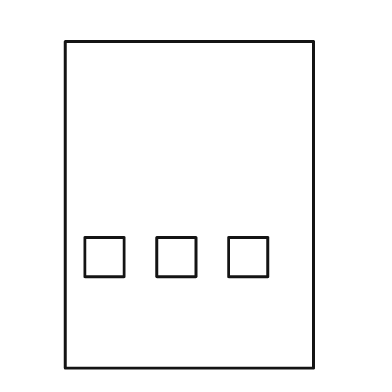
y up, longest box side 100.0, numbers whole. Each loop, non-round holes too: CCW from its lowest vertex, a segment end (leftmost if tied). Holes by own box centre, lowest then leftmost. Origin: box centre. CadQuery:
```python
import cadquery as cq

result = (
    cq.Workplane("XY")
    .moveTo(-38.0, -50.0)
    .lineTo(38.0, -50.0)
    .lineTo(38.0, 50.0)
    .lineTo(-38.0, 50.0)
    .close()
    .moveTo(-32.0, -22.0)
    .lineTo(-20.0, -22.0)
    .lineTo(-20.0, -10.0)
    .lineTo(-32.0, -10.0)
    .close()
    .moveTo(-10.0, -22.0)
    .lineTo(2.0, -22.0)
    .lineTo(2.0, -10.0)
    .lineTo(-10.0, -10.0)
    .close()
    .moveTo(12.0, -22.0)
    .lineTo(24.0, -22.0)
    .lineTo(24.0, -10.0)
    .lineTo(12.0, -10.0)
    .close()
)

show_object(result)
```